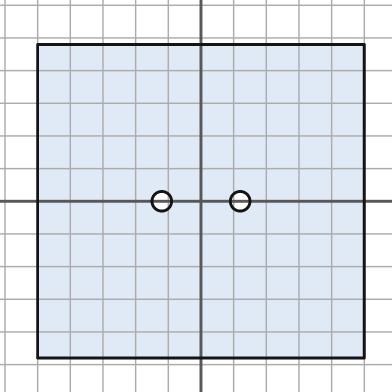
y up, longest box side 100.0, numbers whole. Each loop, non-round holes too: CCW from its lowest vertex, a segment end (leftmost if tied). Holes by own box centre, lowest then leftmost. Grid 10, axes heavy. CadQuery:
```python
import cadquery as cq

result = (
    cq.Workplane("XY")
    .moveTo(-50.0, -48.0)
    .lineTo(50.0, -48.0)
    .lineTo(50.0, 48.0)
    .lineTo(-50.0, 48.0)
    .close()
    .moveTo(-12.0, 0.0)
    .circle(3.0)
    .moveTo(12.0, 0.0)
    .circle(3.0)
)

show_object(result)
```